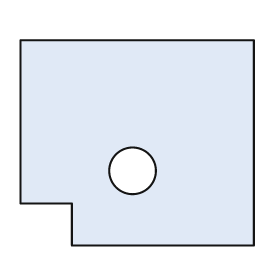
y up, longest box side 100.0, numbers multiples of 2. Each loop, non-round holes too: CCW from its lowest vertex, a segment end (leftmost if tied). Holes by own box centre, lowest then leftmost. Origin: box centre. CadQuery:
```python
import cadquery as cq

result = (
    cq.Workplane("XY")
    .moveTo(-28.0, -44.0)
    .lineTo(50.0, -44.0)
    .lineTo(50.0, 44.0)
    .lineTo(-50.0, 44.0)
    .lineTo(-50.0, -26.0)
    .lineTo(-28.0, -26.0)
    .close()
    .moveTo(-2.0, -12.0)
    .circle(10.0)
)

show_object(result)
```